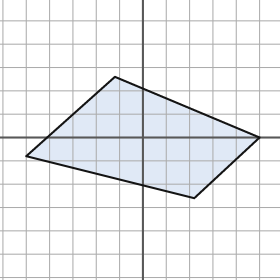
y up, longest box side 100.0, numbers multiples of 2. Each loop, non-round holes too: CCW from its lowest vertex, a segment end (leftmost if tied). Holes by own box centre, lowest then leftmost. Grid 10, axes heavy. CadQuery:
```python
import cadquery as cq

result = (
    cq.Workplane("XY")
    .moveTo(22.0, -26.0)
    .lineTo(50.0, 0.0)
    .lineTo(-12.0, 26.0)
    .lineTo(-50.0, -8.0)
    .close()
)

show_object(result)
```